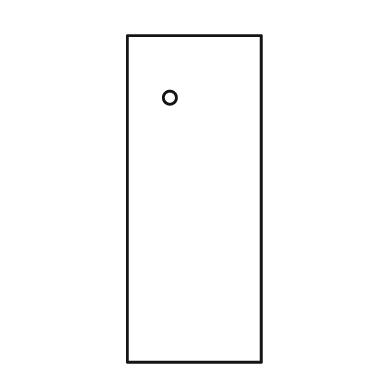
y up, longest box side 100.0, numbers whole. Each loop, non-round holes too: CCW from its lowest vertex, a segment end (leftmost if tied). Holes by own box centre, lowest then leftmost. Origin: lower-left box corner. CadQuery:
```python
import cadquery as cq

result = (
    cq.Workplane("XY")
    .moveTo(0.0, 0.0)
    .lineTo(41.0, 0.0)
    .lineTo(41.0, 100.0)
    .lineTo(0.0, 100.0)
    .close()
    .moveTo(13.0, 81.0)
    .circle(2.0)
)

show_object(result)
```